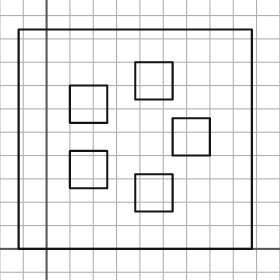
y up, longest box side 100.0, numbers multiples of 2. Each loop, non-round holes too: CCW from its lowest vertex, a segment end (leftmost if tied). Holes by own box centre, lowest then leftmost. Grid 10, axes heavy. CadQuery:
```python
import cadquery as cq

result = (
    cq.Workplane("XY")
    .moveTo(-12.0, 0.0)
    .lineTo(88.0, 0.0)
    .lineTo(88.0, 94.0)
    .lineTo(-12.0, 94.0)
    .close()
    .moveTo(38.0, 16.0)
    .lineTo(54.0, 16.0)
    .lineTo(54.0, 32.0)
    .lineTo(38.0, 32.0)
    .close()
    .moveTo(10.0, 26.0)
    .lineTo(26.0, 26.0)
    .lineTo(26.0, 42.0)
    .lineTo(10.0, 42.0)
    .close()
    .moveTo(54.0, 40.0)
    .lineTo(70.0, 40.0)
    .lineTo(70.0, 56.0)
    .lineTo(54.0, 56.0)
    .close()
    .moveTo(10.0, 54.0)
    .lineTo(26.0, 54.0)
    .lineTo(26.0, 70.0)
    .lineTo(10.0, 70.0)
    .close()
    .moveTo(38.0, 64.0)
    .lineTo(54.0, 64.0)
    .lineTo(54.0, 80.0)
    .lineTo(38.0, 80.0)
    .close()
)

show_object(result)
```